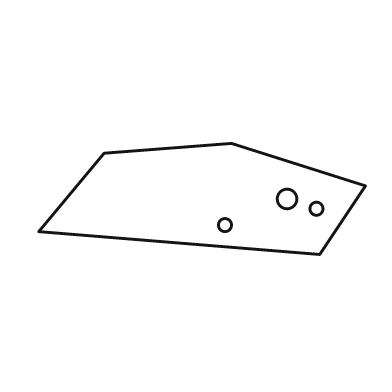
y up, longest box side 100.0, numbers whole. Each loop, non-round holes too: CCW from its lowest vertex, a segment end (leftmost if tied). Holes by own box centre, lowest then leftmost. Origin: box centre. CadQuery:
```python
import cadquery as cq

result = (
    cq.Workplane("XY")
    .moveTo(36.0, -17.0)
    .lineTo(50.0, 4.0)
    .lineTo(9.0, 17.0)
    .lineTo(-30.0, 14.0)
    .lineTo(-50.0, -10.0)
    .close()
    .moveTo(7.0, -8.0)
    .circle(2.0)
    .moveTo(35.0, -3.0)
    .circle(2.0)
    .moveTo(26.0, 0.0)
    .circle(3.0)
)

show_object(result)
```